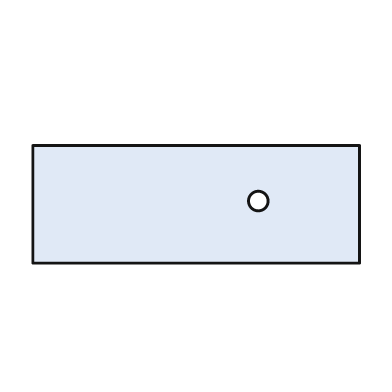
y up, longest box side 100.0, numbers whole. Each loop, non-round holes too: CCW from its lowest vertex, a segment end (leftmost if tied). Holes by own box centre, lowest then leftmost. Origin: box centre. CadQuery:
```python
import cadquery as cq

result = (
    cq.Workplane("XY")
    .moveTo(-50.0, -18.0)
    .lineTo(50.0, -18.0)
    .lineTo(50.0, 18.0)
    .lineTo(-50.0, 18.0)
    .close()
    .moveTo(19.0, 1.0)
    .circle(3.0)
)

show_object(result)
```